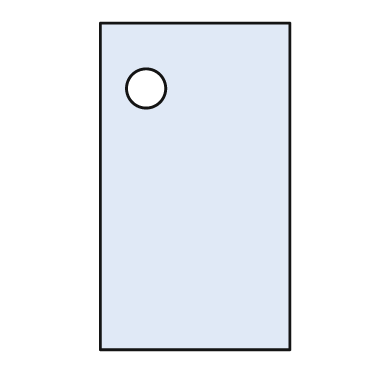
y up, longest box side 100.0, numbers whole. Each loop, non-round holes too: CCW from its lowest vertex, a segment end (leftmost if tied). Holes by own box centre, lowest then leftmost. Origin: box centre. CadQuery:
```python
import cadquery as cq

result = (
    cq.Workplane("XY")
    .moveTo(-29.0, -50.0)
    .lineTo(29.0, -50.0)
    .lineTo(29.0, 50.0)
    .lineTo(-29.0, 50.0)
    .close()
    .moveTo(-15.0, 30.0)
    .circle(6.0)
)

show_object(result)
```